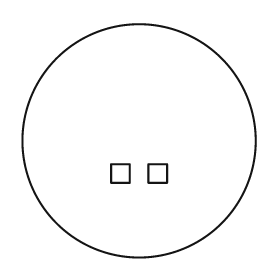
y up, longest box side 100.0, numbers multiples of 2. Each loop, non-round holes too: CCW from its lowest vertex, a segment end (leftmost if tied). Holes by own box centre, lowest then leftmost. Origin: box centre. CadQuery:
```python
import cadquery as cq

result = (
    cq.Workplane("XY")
    .moveTo(0.0, 0.0)
    .circle(50.0)
    .moveTo(-12.0, -18.0)
    .lineTo(-4.0, -18.0)
    .lineTo(-4.0, -10.0)
    .lineTo(-12.0, -10.0)
    .close()
    .moveTo(4.0, -18.0)
    .lineTo(12.0, -18.0)
    .lineTo(12.0, -10.0)
    .lineTo(4.0, -10.0)
    .close()
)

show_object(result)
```